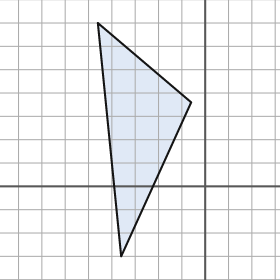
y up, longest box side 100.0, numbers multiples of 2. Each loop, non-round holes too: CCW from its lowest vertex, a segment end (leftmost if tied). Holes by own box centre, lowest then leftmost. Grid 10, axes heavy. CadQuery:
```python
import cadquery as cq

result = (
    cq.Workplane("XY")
    .moveTo(-36.0, -30.0)
    .lineTo(-6.0, 36.0)
    .lineTo(-46.0, 70.0)
    .close()
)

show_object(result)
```